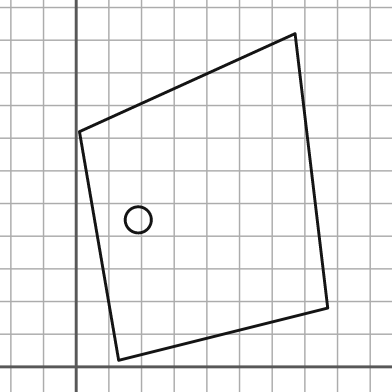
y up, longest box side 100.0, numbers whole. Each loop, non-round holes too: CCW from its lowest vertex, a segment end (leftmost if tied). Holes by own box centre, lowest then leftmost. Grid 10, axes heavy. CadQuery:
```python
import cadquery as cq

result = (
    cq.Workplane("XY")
    .moveTo(13.0, 2.0)
    .lineTo(77.0, 18.0)
    .lineTo(67.0, 102.0)
    .lineTo(1.0, 72.0)
    .close()
    .moveTo(19.0, 45.0)
    .circle(4.0)
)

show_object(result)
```